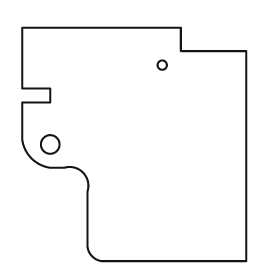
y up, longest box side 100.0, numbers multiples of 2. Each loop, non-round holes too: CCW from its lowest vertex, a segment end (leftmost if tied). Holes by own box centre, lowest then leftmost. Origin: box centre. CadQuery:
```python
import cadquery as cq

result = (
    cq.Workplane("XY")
    .moveTo(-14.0, -50.0)
    .lineTo(48.0, -50.0)
    .lineTo(48.0, 40.0)
    .lineTo(20.0, 40.0)
    .lineTo(20.0, 50.0)
    .lineTo(-48.0, 50.0)
    .lineTo(-48.0, 24.0)
    .lineTo(-36.0, 24.0)
    .lineTo(-36.0, 18.0)
    .lineTo(-48.0, 18.0)
    .lineTo(-48.0, 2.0)
    .threePointArc((-44.0, -6.0), (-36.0, -10.0))
    .lineTo(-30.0, -10.0)
    .threePointArc((-22.0, -12.0), (-20.0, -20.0))
    .lineTo(-20.0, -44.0)
    .threePointArc((-18.0, -48.0), (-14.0, -50.0))
    .close()
    .moveTo(-36.0, 0.0)
    .circle(4.0)
    .moveTo(12.0, 34.0)
    .circle(2.0)
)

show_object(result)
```